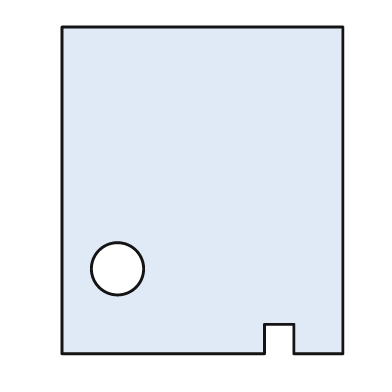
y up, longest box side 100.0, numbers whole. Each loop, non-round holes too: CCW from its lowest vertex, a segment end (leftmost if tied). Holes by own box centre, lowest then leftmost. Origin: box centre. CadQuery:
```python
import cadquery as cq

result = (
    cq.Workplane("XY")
    .moveTo(-43.0, -50.0)
    .lineTo(19.0, -50.0)
    .lineTo(19.0, -41.0)
    .lineTo(28.0, -41.0)
    .lineTo(28.0, -50.0)
    .lineTo(43.0, -50.0)
    .lineTo(43.0, 50.0)
    .lineTo(-43.0, 50.0)
    .close()
    .moveTo(-26.0, -24.0)
    .circle(8.0)
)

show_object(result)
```